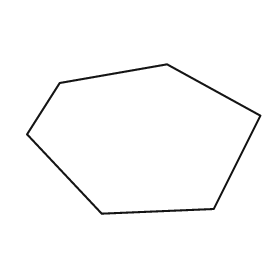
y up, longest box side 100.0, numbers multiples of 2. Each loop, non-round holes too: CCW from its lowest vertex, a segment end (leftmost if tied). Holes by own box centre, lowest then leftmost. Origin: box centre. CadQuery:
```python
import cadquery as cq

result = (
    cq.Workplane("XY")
    .moveTo(-18.0, -32.0)
    .lineTo(30.0, -30.0)
    .lineTo(50.0, 10.0)
    .lineTo(10.0, 32.0)
    .lineTo(-36.0, 24.0)
    .lineTo(-50.0, 2.0)
    .close()
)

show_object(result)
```